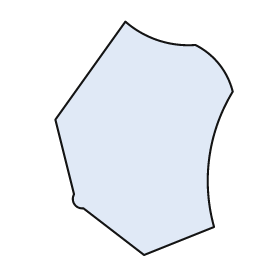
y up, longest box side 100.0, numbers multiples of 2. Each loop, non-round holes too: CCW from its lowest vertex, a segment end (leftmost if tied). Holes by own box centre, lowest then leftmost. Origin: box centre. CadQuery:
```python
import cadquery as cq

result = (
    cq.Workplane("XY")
    .moveTo(0.0, -50.0)
    .lineTo(30.0, -38.0)
    .threePointArc((28.0, -8.0), (38.0, 20.0))
    .threePointArc((32.0, 32.0), (22.0, 40.0))
    .threePointArc((6.0, 42.0), (-8.0, 50.0))
    .lineTo(-38.0, 8.0)
    .lineTo(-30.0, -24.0)
    .threePointArc((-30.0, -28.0), (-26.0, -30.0))
    .close()
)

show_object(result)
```